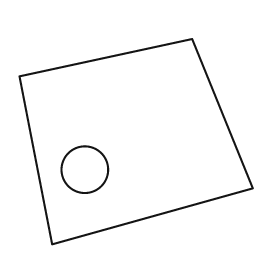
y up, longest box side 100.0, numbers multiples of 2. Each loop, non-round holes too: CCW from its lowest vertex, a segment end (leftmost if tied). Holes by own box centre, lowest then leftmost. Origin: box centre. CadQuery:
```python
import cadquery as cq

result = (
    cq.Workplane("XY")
    .moveTo(-36.0, -44.0)
    .lineTo(50.0, -20.0)
    .lineTo(24.0, 44.0)
    .lineTo(-50.0, 28.0)
    .close()
    .moveTo(-22.0, -12.0)
    .circle(10.0)
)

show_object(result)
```